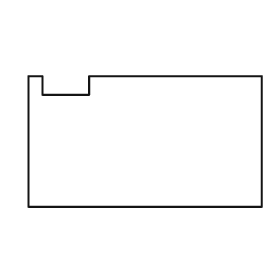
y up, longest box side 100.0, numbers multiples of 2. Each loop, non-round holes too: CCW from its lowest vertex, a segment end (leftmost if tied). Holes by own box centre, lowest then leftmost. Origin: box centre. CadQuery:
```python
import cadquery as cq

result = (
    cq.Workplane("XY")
    .moveTo(-50.0, -28.0)
    .lineTo(50.0, -28.0)
    .lineTo(50.0, 28.0)
    .lineTo(-24.0, 28.0)
    .lineTo(-24.0, 20.0)
    .lineTo(-44.0, 20.0)
    .lineTo(-44.0, 28.0)
    .lineTo(-50.0, 28.0)
    .close()
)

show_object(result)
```